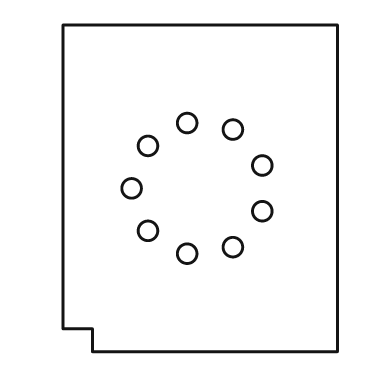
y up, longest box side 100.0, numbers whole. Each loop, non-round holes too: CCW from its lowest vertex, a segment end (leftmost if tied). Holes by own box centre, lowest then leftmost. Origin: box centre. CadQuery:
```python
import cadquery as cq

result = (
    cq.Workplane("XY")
    .moveTo(-33.0, -50.0)
    .lineTo(42.0, -50.0)
    .lineTo(42.0, 50.0)
    .lineTo(-42.0, 50.0)
    .lineTo(-42.0, -43.0)
    .lineTo(-33.0, -43.0)
    .close()
    .moveTo(-4.0, -20.0)
    .circle(3.0)
    .moveTo(10.0, -18.0)
    .circle(3.0)
    .moveTo(-16.0, -13.0)
    .circle(3.0)
    .moveTo(19.0, -7.0)
    .circle(3.0)
    .moveTo(-21.0, 0.0)
    .circle(3.0)
    .moveTo(19.0, 7.0)
    .circle(3.0)
    .moveTo(-16.0, 13.0)
    .circle(3.0)
    .moveTo(10.0, 18.0)
    .circle(3.0)
    .moveTo(-4.0, 20.0)
    .circle(3.0)
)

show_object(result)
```